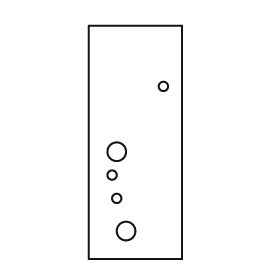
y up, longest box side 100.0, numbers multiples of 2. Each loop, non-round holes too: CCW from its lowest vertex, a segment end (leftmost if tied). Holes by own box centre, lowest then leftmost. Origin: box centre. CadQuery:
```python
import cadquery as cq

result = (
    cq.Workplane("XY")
    .moveTo(-20.0, -50.0)
    .lineTo(20.0, -50.0)
    .lineTo(20.0, 50.0)
    .lineTo(-20.0, 50.0)
    .close()
    .moveTo(-4.0, -38.0)
    .circle(4.0)
    .moveTo(-8.0, -24.0)
    .circle(2.0)
    .moveTo(-10.0, -14.0)
    .circle(2.0)
    .moveTo(-8.0, -4.0)
    .circle(4.0)
    .moveTo(12.0, 24.0)
    .circle(2.0)
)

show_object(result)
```